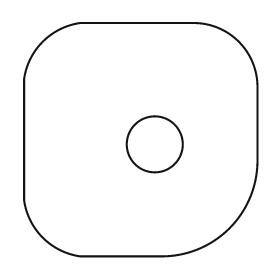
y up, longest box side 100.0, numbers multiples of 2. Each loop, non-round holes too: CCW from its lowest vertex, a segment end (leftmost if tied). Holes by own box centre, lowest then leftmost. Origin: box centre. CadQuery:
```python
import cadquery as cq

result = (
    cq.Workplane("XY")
    .moveTo(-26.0, -50.0)
    .lineTo(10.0, -50.0)
    .threePointArc((38.0, -38.0), (50.0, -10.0))
    .lineTo(50.0, 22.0)
    .threePointArc((42.0, 42.0), (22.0, 50.0))
    .lineTo(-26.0, 50.0)
    .threePointArc((-42.0, 42.0), (-50.0, 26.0))
    .lineTo(-50.0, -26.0)
    .threePointArc((-42.0, -42.0), (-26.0, -50.0))
    .close()
    .moveTo(6.0, -2.0)
    .circle(12.0)
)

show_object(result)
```